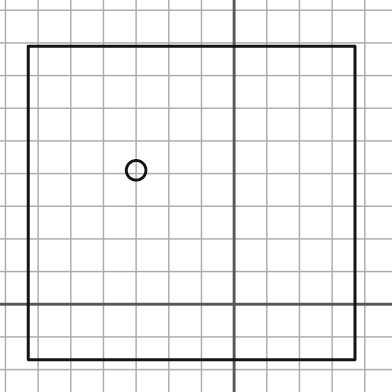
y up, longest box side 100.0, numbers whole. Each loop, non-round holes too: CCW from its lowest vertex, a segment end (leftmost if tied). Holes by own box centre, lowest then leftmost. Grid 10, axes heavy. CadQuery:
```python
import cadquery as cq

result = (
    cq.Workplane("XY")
    .moveTo(-63.0, -17.0)
    .lineTo(37.0, -17.0)
    .lineTo(37.0, 79.0)
    .lineTo(-63.0, 79.0)
    .close()
    .moveTo(-30.0, 41.0)
    .circle(3.0)
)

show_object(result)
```